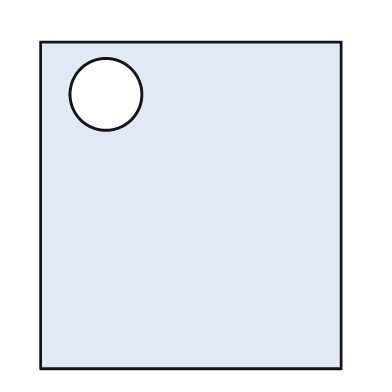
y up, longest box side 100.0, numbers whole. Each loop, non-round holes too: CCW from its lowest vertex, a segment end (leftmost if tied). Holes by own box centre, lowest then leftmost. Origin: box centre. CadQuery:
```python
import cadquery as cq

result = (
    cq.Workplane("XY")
    .moveTo(-46.0, -50.0)
    .lineTo(46.0, -50.0)
    .lineTo(46.0, 50.0)
    .lineTo(-46.0, 50.0)
    .close()
    .moveTo(-26.0, 34.0)
    .circle(11.0)
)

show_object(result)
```